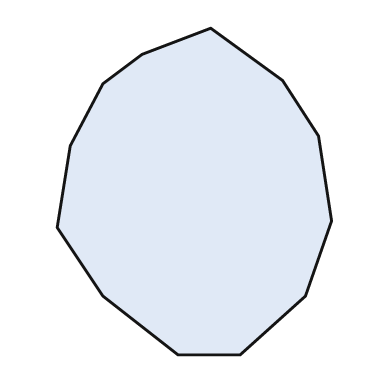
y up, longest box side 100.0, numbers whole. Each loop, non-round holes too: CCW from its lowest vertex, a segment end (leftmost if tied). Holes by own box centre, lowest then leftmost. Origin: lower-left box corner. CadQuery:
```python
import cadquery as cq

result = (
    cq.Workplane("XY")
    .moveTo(37.0, 0.0)
    .lineTo(56.0, 0.0)
    .lineTo(76.0, 18.0)
    .lineTo(84.0, 41.0)
    .lineTo(80.0, 67.0)
    .lineTo(69.0, 84.0)
    .lineTo(47.0, 100.0)
    .lineTo(26.0, 92.0)
    .lineTo(14.0, 83.0)
    .lineTo(4.0, 64.0)
    .lineTo(0.0, 39.0)
    .lineTo(14.0, 18.0)
    .close()
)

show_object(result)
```